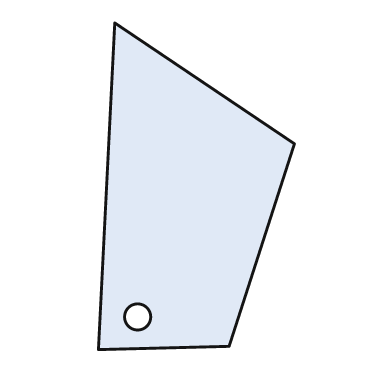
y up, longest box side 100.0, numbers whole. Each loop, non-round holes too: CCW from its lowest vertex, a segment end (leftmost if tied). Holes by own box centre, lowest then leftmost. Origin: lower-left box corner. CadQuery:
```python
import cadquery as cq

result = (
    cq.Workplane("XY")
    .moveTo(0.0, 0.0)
    .lineTo(40.0, 1.0)
    .lineTo(60.0, 63.0)
    .lineTo(5.0, 100.0)
    .close()
    .moveTo(12.0, 10.0)
    .circle(4.0)
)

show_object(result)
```